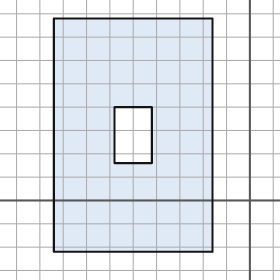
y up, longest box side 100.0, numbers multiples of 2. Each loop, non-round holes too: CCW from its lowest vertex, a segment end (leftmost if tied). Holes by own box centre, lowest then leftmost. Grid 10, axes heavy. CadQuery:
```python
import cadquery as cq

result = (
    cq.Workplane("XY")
    .moveTo(-84.0, -22.0)
    .lineTo(-16.0, -22.0)
    .lineTo(-16.0, 78.0)
    .lineTo(-84.0, 78.0)
    .close()
    .moveTo(-58.0, 16.0)
    .lineTo(-42.0, 16.0)
    .lineTo(-42.0, 40.0)
    .lineTo(-58.0, 40.0)
    .close()
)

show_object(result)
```